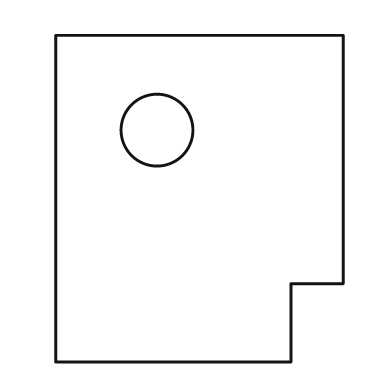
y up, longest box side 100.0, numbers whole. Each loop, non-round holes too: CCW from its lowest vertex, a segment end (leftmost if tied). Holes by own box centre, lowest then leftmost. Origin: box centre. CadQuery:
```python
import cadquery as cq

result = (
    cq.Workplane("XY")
    .moveTo(-44.0, -50.0)
    .lineTo(28.0, -50.0)
    .lineTo(28.0, -26.0)
    .lineTo(44.0, -26.0)
    .lineTo(44.0, 50.0)
    .lineTo(-44.0, 50.0)
    .close()
    .moveTo(-13.0, 21.0)
    .circle(11.0)
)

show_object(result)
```